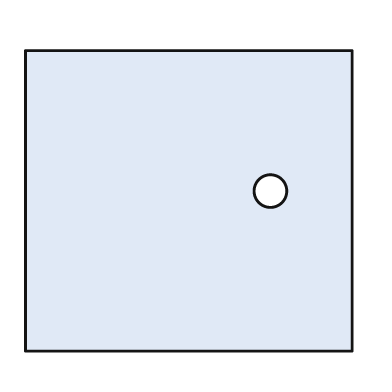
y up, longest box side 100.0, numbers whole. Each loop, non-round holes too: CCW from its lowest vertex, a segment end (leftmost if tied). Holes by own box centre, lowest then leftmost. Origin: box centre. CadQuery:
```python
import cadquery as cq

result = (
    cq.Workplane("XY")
    .moveTo(-50.0, -46.0)
    .lineTo(50.0, -46.0)
    .lineTo(50.0, 46.0)
    .lineTo(-50.0, 46.0)
    .close()
    .moveTo(25.0, 3.0)
    .circle(5.0)
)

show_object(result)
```